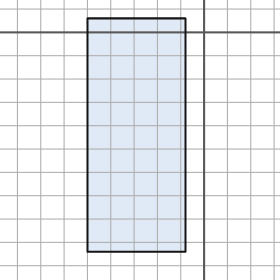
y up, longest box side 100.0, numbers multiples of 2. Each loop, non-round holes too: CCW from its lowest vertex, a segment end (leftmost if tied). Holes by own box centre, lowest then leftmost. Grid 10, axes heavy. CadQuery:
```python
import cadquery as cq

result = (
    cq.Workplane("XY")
    .moveTo(-50.0, -94.0)
    .lineTo(-8.0, -94.0)
    .lineTo(-8.0, 6.0)
    .lineTo(-50.0, 6.0)
    .close()
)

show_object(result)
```